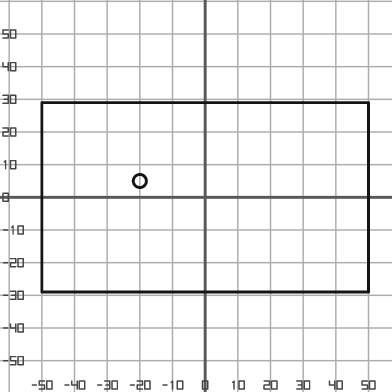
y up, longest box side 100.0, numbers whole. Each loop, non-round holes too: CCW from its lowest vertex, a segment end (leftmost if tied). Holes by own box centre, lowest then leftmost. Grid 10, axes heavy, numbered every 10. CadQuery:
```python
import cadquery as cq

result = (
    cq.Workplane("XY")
    .moveTo(-50.0, -29.0)
    .lineTo(50.0, -29.0)
    .lineTo(50.0, 29.0)
    .lineTo(-50.0, 29.0)
    .close()
    .moveTo(-20.0, 5.0)
    .circle(2.0)
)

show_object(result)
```